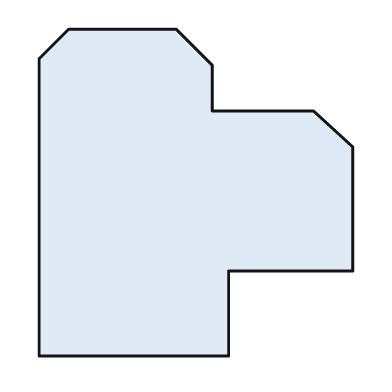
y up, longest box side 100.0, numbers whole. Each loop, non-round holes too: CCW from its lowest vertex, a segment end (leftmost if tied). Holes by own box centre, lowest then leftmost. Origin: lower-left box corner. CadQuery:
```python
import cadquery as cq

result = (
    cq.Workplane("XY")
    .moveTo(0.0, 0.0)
    .lineTo(58.0, 0.0)
    .lineTo(58.0, 26.0)
    .lineTo(96.0, 26.0)
    .lineTo(96.0, 64.0)
    .lineTo(84.0, 75.0)
    .lineTo(53.0, 75.0)
    .lineTo(53.0, 89.0)
    .lineTo(42.0, 100.0)
    .lineTo(9.0, 100.0)
    .lineTo(0.0, 91.0)
    .close()
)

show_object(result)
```